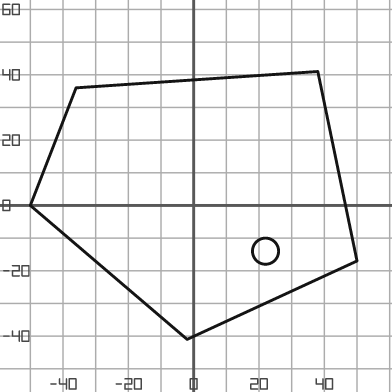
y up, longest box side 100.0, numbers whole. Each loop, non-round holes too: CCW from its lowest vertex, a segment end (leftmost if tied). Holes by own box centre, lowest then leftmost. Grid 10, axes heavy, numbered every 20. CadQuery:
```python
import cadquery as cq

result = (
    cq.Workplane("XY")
    .moveTo(-2.0, -41.0)
    .lineTo(50.0, -17.0)
    .lineTo(38.0, 41.0)
    .lineTo(-36.0, 36.0)
    .lineTo(-50.0, 0.0)
    .close()
    .moveTo(22.0, -14.0)
    .circle(4.0)
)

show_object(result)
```